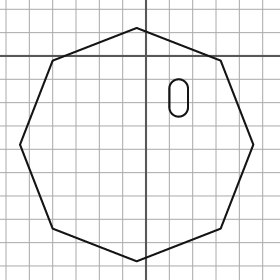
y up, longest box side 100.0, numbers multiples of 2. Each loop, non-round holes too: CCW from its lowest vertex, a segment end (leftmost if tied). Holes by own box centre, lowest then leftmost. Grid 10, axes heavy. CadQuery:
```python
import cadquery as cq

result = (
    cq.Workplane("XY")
    .moveTo(-4.0, -88.0)
    .lineTo(32.0, -74.0)
    .lineTo(46.0, -38.0)
    .lineTo(32.0, -2.0)
    .lineTo(-4.0, 12.0)
    .lineTo(-40.0, -2.0)
    .lineTo(-54.0, -38.0)
    .lineTo(-40.0, -74.0)
    .close()
    .moveTo(10.0, -22.0)
    .threePointArc((14.0, -26.0), (18.0, -22.0))
    .lineTo(18.0, -14.0)
    .threePointArc((14.0, -10.0), (10.0, -14.0))
    .close()
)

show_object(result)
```